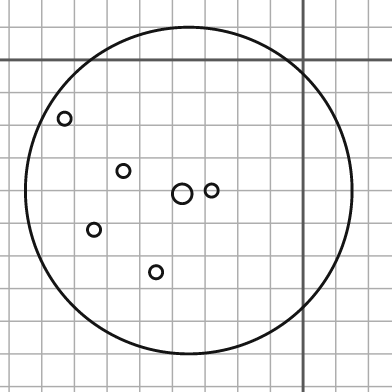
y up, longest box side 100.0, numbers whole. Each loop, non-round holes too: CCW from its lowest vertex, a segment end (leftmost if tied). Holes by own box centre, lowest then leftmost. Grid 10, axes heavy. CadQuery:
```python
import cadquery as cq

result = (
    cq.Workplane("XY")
    .moveTo(-35.0, -40.0)
    .circle(50.0)
    .moveTo(-45.0, -65.0)
    .circle(2.0)
    .moveTo(-64.0, -52.0)
    .circle(2.0)
    .moveTo(-37.0, -41.0)
    .circle(3.0)
    .moveTo(-28.0, -40.0)
    .circle(2.0)
    .moveTo(-55.0, -34.0)
    .circle(2.0)
    .moveTo(-73.0, -18.0)
    .circle(2.0)
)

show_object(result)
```